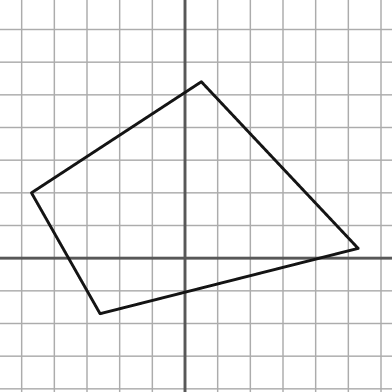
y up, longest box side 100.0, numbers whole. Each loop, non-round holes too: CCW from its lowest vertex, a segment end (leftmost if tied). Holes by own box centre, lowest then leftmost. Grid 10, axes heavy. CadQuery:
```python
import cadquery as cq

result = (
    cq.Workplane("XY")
    .moveTo(-26.0, -17.0)
    .lineTo(53.0, 3.0)
    .lineTo(5.0, 54.0)
    .lineTo(-47.0, 20.0)
    .close()
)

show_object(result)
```